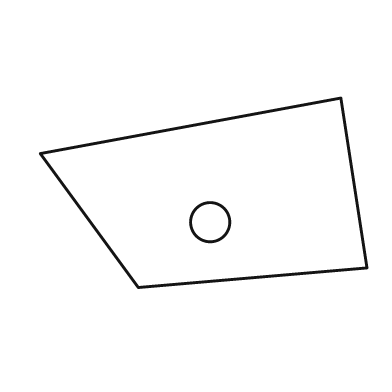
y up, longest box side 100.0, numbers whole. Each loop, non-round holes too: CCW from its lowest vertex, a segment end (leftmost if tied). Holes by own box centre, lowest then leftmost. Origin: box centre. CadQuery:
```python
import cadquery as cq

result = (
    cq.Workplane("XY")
    .moveTo(-20.0, -29.0)
    .lineTo(50.0, -23.0)
    .lineTo(42.0, 29.0)
    .lineTo(-50.0, 12.0)
    .close()
    .moveTo(2.0, -9.0)
    .circle(6.0)
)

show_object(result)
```